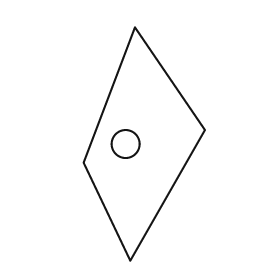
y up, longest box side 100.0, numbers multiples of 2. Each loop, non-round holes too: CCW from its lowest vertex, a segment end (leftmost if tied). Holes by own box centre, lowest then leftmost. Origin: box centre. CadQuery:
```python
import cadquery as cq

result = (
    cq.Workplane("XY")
    .moveTo(-6.0, -50.0)
    .lineTo(26.0, 6.0)
    .lineTo(-4.0, 50.0)
    .lineTo(-26.0, -8.0)
    .close()
    .moveTo(-8.0, 0.0)
    .circle(6.0)
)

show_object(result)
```